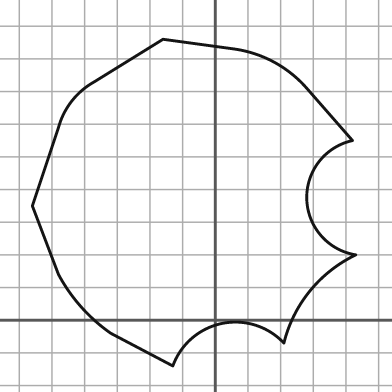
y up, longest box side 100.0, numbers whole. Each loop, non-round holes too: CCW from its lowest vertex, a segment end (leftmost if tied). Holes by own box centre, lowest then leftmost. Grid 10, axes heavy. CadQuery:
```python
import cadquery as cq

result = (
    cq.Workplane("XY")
    .moveTo(-13.0, -14.0)
    .threePointArc((2.0, -1.0), (21.0, -7.0))
    .threePointArc((29.0, 9.0), (43.0, 20.0))
    .threePointArc((28.0, 37.0), (42.0, 55.0))
    .lineTo(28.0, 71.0)
    .threePointArc((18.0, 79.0), (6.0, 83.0))
    .lineTo(-16.0, 86.0)
    .lineTo(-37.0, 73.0)
    .threePointArc((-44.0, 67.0), (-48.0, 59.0))
    .lineTo(-56.0, 35.0)
    .lineTo(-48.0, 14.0)
    .threePointArc((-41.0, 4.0), (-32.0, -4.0))
    .close()
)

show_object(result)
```